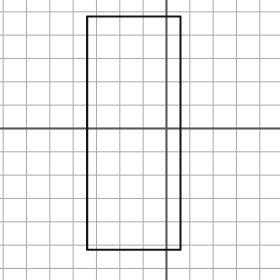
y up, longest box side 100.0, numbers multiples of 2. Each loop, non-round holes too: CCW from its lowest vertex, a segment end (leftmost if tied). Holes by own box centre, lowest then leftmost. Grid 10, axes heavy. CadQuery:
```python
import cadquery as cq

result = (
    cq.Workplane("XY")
    .moveTo(-34.0, -52.0)
    .lineTo(6.0, -52.0)
    .lineTo(6.0, 48.0)
    .lineTo(-34.0, 48.0)
    .close()
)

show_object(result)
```